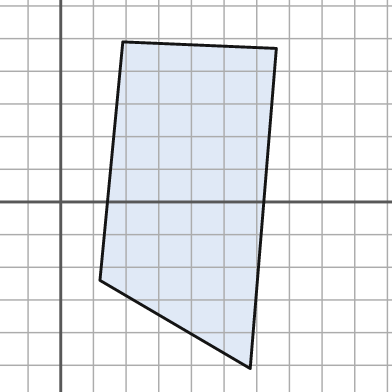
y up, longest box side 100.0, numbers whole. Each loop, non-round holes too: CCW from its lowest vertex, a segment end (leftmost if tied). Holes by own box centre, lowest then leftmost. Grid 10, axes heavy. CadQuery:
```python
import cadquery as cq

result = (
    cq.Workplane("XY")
    .moveTo(58.0, -51.0)
    .lineTo(66.0, 47.0)
    .lineTo(19.0, 49.0)
    .lineTo(12.0, -24.0)
    .close()
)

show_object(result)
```